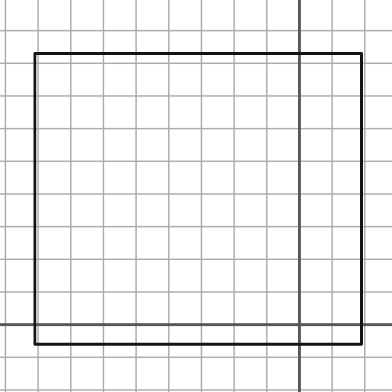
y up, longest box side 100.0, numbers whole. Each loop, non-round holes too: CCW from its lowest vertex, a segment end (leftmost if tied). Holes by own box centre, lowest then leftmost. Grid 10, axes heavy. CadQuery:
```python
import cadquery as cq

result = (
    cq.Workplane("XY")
    .moveTo(-81.0, -6.0)
    .lineTo(19.0, -6.0)
    .lineTo(19.0, 83.0)
    .lineTo(-81.0, 83.0)
    .close()
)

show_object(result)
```